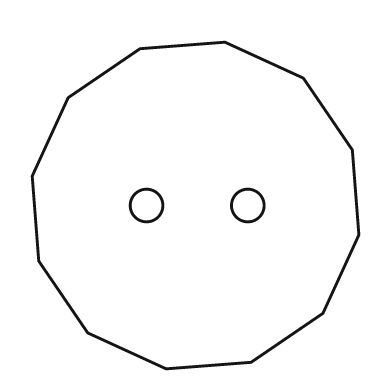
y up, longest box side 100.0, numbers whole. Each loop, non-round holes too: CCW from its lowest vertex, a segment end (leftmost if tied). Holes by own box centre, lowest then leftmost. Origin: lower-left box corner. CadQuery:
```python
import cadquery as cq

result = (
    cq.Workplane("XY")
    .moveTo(41.0, 0.0)
    .lineTo(67.0, 2.0)
    .lineTo(89.0, 17.0)
    .lineTo(100.0, 41.0)
    .lineTo(98.0, 67.0)
    .lineTo(83.0, 89.0)
    .lineTo(59.0, 100.0)
    .lineTo(33.0, 98.0)
    .lineTo(11.0, 83.0)
    .lineTo(0.0, 59.0)
    .lineTo(2.0, 33.0)
    .lineTo(17.0, 11.0)
    .close()
    .moveTo(35.0, 50.0)
    .circle(5.0)
    .moveTo(66.0, 50.0)
    .circle(5.0)
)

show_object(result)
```